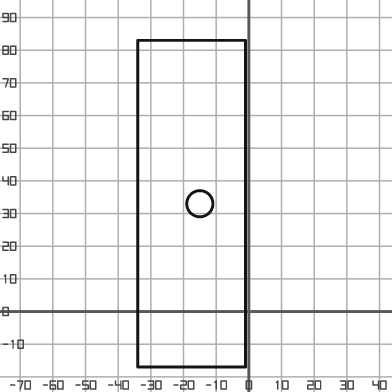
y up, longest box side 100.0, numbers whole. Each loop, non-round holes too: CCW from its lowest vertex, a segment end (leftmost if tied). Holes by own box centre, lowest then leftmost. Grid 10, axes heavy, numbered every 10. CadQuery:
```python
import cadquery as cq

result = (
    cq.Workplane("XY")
    .moveTo(-34.0, -17.0)
    .lineTo(-1.0, -17.0)
    .lineTo(-1.0, 83.0)
    .lineTo(-34.0, 83.0)
    .close()
    .moveTo(-15.0, 33.0)
    .circle(4.0)
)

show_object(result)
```